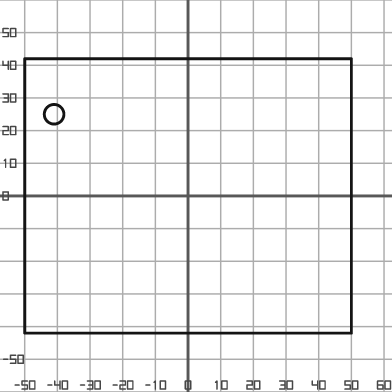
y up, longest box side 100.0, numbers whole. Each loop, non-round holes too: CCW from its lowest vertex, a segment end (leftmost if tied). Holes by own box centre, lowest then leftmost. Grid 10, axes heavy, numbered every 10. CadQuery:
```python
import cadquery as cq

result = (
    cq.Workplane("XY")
    .moveTo(-50.0, -42.0)
    .lineTo(50.0, -42.0)
    .lineTo(50.0, 42.0)
    .lineTo(-50.0, 42.0)
    .close()
    .moveTo(-41.0, 25.0)
    .circle(3.0)
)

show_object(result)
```